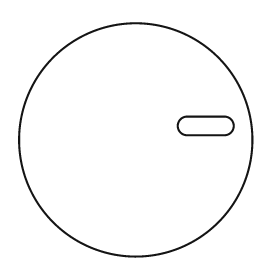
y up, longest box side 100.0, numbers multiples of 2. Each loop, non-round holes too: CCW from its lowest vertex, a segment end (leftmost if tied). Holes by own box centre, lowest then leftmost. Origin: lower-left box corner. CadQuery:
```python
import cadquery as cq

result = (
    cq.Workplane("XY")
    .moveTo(50.0, 50.0)
    .circle(50.0)
    .moveTo(72.0, 52.0)
    .lineTo(88.0, 52.0)
    .threePointArc((92.0, 56.0), (88.0, 60.0))
    .lineTo(72.0, 60.0)
    .threePointArc((68.0, 56.0), (72.0, 52.0))
    .close()
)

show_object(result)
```